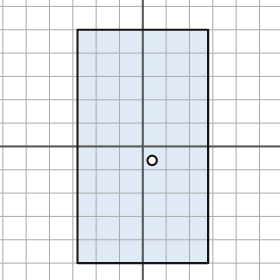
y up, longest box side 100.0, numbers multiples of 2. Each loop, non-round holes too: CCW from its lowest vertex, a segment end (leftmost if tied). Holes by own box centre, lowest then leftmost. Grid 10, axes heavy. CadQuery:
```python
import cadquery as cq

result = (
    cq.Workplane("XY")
    .moveTo(-28.0, -50.0)
    .lineTo(28.0, -50.0)
    .lineTo(28.0, 50.0)
    .lineTo(-28.0, 50.0)
    .close()
    .moveTo(4.0, -6.0)
    .circle(2.0)
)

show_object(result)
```